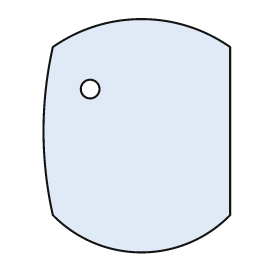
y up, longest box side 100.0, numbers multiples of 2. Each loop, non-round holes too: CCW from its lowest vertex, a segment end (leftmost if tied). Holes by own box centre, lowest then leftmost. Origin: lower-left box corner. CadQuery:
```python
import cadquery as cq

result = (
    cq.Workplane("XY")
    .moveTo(4.0, 16.0)
    .threePointArc((42.0, 0.0), (80.0, 16.0))
    .lineTo(80.0, 88.0)
    .threePointArc((42.0, 100.0), (4.0, 88.0))
    .threePointArc((0.0, 52.0), (4.0, 16.0))
    .close()
    .moveTo(20.0, 70.0)
    .circle(4.0)
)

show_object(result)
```